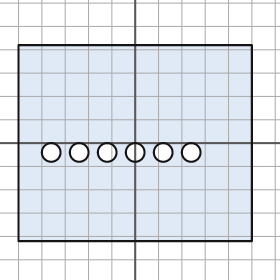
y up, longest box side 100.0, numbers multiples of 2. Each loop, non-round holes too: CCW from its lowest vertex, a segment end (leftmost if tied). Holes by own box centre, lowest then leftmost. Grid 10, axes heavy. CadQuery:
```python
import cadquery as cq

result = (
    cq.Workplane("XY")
    .moveTo(-50.0, -42.0)
    .lineTo(50.0, -42.0)
    .lineTo(50.0, 42.0)
    .lineTo(-50.0, 42.0)
    .close()
    .moveTo(-36.0, -4.0)
    .circle(4.0)
    .moveTo(-24.0, -4.0)
    .circle(4.0)
    .moveTo(-12.0, -4.0)
    .circle(4.0)
    .moveTo(0.0, -4.0)
    .circle(4.0)
    .moveTo(12.0, -4.0)
    .circle(4.0)
    .moveTo(24.0, -4.0)
    .circle(4.0)
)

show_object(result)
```